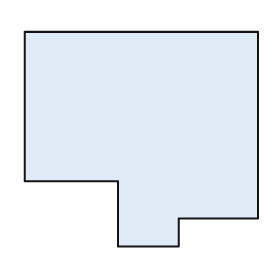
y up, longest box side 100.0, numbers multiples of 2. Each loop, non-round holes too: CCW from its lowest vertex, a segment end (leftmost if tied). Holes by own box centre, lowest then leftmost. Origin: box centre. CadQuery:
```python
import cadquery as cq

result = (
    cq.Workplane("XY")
    .moveTo(-10.0, -46.0)
    .lineTo(16.0, -46.0)
    .lineTo(16.0, -34.0)
    .lineTo(50.0, -34.0)
    .lineTo(50.0, 46.0)
    .lineTo(-50.0, 46.0)
    .lineTo(-50.0, -18.0)
    .lineTo(-10.0, -18.0)
    .close()
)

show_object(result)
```